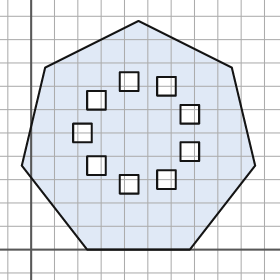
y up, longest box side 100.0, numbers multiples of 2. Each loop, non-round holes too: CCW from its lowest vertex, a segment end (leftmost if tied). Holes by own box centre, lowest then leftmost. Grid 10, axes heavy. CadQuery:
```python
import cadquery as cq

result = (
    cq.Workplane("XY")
    .moveTo(24.0, 0.0)
    .lineTo(68.0, 0.0)
    .lineTo(96.0, 36.0)
    .lineTo(86.0, 78.0)
    .lineTo(46.0, 98.0)
    .lineTo(6.0, 78.0)
    .lineTo(-4.0, 36.0)
    .close()
    .moveTo(38.0, 24.0)
    .lineTo(46.0, 24.0)
    .lineTo(46.0, 32.0)
    .lineTo(38.0, 32.0)
    .close()
    .moveTo(54.0, 26.0)
    .lineTo(62.0, 26.0)
    .lineTo(62.0, 34.0)
    .lineTo(54.0, 34.0)
    .close()
    .moveTo(24.0, 32.0)
    .lineTo(32.0, 32.0)
    .lineTo(32.0, 40.0)
    .lineTo(24.0, 40.0)
    .close()
    .moveTo(64.0, 38.0)
    .lineTo(72.0, 38.0)
    .lineTo(72.0, 46.0)
    .lineTo(64.0, 46.0)
    .close()
    .moveTo(18.0, 46.0)
    .lineTo(26.0, 46.0)
    .lineTo(26.0, 54.0)
    .lineTo(18.0, 54.0)
    .close()
    .moveTo(64.0, 54.0)
    .lineTo(72.0, 54.0)
    .lineTo(72.0, 62.0)
    .lineTo(64.0, 62.0)
    .close()
    .moveTo(24.0, 60.0)
    .lineTo(32.0, 60.0)
    .lineTo(32.0, 68.0)
    .lineTo(24.0, 68.0)
    .close()
    .moveTo(54.0, 66.0)
    .lineTo(62.0, 66.0)
    .lineTo(62.0, 74.0)
    .lineTo(54.0, 74.0)
    .close()
    .moveTo(38.0, 68.0)
    .lineTo(46.0, 68.0)
    .lineTo(46.0, 76.0)
    .lineTo(38.0, 76.0)
    .close()
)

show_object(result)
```